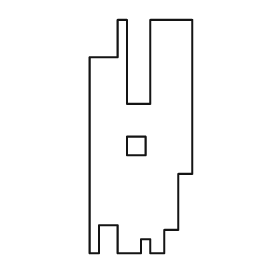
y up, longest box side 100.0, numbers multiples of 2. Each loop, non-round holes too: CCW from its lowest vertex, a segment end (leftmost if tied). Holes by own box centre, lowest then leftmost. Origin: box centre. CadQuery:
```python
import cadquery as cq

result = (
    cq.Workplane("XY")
    .moveTo(-22.0, -50.0)
    .lineTo(-18.0, -50.0)
    .lineTo(-18.0, -38.0)
    .lineTo(-10.0, -38.0)
    .lineTo(-10.0, -50.0)
    .lineTo(0.0, -50.0)
    .lineTo(0.0, -44.0)
    .lineTo(4.0, -44.0)
    .lineTo(4.0, -50.0)
    .lineTo(10.0, -50.0)
    .lineTo(10.0, -40.0)
    .lineTo(16.0, -40.0)
    .lineTo(16.0, -16.0)
    .lineTo(22.0, -16.0)
    .lineTo(22.0, 50.0)
    .lineTo(4.0, 50.0)
    .lineTo(4.0, 14.0)
    .lineTo(-6.0, 14.0)
    .lineTo(-6.0, 50.0)
    .lineTo(-10.0, 50.0)
    .lineTo(-10.0, 34.0)
    .lineTo(-22.0, 34.0)
    .close()
    .moveTo(-6.0, -8.0)
    .lineTo(2.0, -8.0)
    .lineTo(2.0, 0.0)
    .lineTo(-6.0, 0.0)
    .close()
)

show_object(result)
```